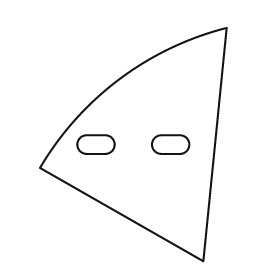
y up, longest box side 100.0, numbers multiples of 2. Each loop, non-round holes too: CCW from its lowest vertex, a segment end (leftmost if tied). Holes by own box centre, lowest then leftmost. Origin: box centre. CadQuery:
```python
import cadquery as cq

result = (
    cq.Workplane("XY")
    .moveTo(30.0, -50.0)
    .lineTo(40.0, 50.0)
    .threePointArc((-6.0, 28.0), (-40.0, -10.0))
    .close()
    .moveTo(-20.0, -4.0)
    .lineTo(-12.0, -4.0)
    .threePointArc((-8.0, 0.0), (-12.0, 4.0))
    .lineTo(-20.0, 4.0)
    .threePointArc((-24.0, 0.0), (-20.0, -4.0))
    .close()
    .moveTo(12.0, -4.0)
    .lineTo(20.0, -4.0)
    .threePointArc((24.0, 0.0), (20.0, 4.0))
    .lineTo(12.0, 4.0)
    .threePointArc((8.0, 0.0), (12.0, -4.0))
    .close()
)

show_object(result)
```